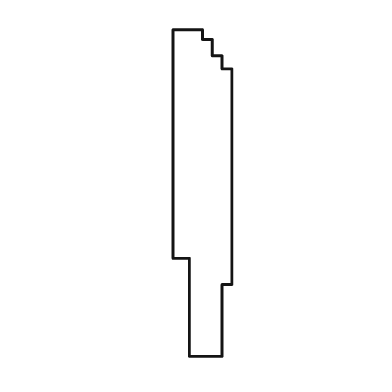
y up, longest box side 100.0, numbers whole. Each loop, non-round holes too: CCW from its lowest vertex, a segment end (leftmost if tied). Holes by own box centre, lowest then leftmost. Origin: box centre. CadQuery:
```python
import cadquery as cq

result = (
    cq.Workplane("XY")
    .moveTo(-4.0, -50.0)
    .lineTo(6.0, -50.0)
    .lineTo(6.0, -28.0)
    .lineTo(9.0, -28.0)
    .lineTo(9.0, 38.0)
    .lineTo(6.0, 38.0)
    .lineTo(6.0, 42.0)
    .lineTo(3.0, 42.0)
    .lineTo(3.0, 47.0)
    .lineTo(0.0, 47.0)
    .lineTo(0.0, 50.0)
    .lineTo(-9.0, 50.0)
    .lineTo(-9.0, -20.0)
    .lineTo(-4.0, -20.0)
    .close()
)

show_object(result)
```